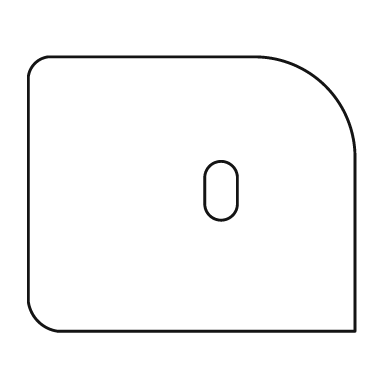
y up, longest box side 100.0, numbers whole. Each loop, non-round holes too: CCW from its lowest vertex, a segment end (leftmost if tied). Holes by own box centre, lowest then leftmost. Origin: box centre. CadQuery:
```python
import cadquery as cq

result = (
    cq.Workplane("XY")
    .moveTo(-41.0, -42.0)
    .lineTo(50.0, -42.0)
    .lineTo(50.0, 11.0)
    .threePointArc((41.0, 33.0), (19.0, 42.0))
    .lineTo(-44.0, 42.0)
    .threePointArc((-48.0, 40.0), (-50.0, 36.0))
    .lineTo(-50.0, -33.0)
    .threePointArc((-47.0, -39.0), (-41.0, -42.0))
    .close()
    .moveTo(4.0, -3.0)
    .threePointArc((9.0, -8.0), (14.0, -3.0))
    .lineTo(14.0, 5.0)
    .threePointArc((9.0, 10.0), (4.0, 5.0))
    .close()
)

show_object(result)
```